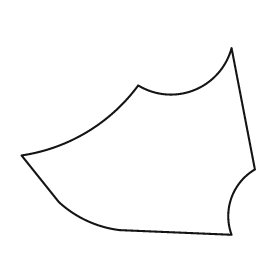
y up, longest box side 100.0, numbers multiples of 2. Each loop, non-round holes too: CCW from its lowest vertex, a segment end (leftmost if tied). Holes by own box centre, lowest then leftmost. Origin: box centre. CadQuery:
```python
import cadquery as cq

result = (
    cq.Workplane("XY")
    .moveTo(40.0, -40.0)
    .threePointArc((40.0, -24.0), (50.0, -12.0))
    .lineTo(40.0, 40.0)
    .threePointArc((24.0, 22.0), (0.0, 24.0))
    .threePointArc((-22.0, 4.0), (-50.0, -6.0))
    .lineTo(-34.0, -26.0)
    .threePointArc((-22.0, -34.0), (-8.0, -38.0))
    .close()
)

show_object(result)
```